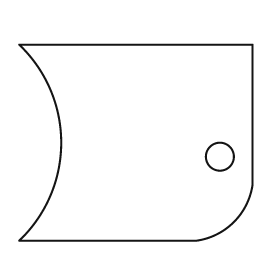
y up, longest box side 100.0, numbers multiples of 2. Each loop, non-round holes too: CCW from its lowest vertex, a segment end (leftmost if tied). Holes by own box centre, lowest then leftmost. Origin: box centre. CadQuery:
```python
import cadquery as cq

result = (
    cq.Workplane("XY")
    .moveTo(-50.0, -42.0)
    .lineTo(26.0, -42.0)
    .threePointArc((42.0, -34.0), (50.0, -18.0))
    .lineTo(50.0, 42.0)
    .lineTo(-50.0, 42.0)
    .threePointArc((-32.0, 0.0), (-50.0, -42.0))
    .close()
    .moveTo(36.0, -6.0)
    .circle(6.0)
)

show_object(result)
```